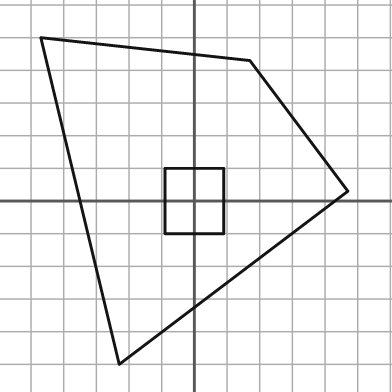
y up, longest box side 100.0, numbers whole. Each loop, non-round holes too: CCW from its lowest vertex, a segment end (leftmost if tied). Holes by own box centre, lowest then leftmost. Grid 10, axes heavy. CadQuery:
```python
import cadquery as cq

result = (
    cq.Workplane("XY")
    .moveTo(-23.0, -50.0)
    .lineTo(47.0, 3.0)
    .lineTo(17.0, 43.0)
    .lineTo(-47.0, 50.0)
    .close()
    .moveTo(-9.0, -10.0)
    .lineTo(9.0, -10.0)
    .lineTo(9.0, 10.0)
    .lineTo(-9.0, 10.0)
    .close()
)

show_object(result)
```